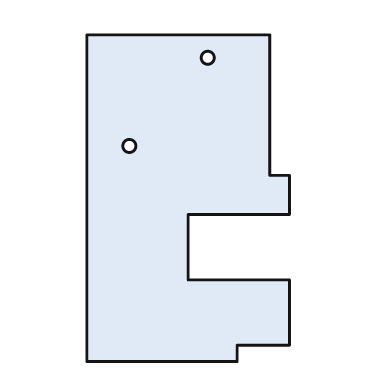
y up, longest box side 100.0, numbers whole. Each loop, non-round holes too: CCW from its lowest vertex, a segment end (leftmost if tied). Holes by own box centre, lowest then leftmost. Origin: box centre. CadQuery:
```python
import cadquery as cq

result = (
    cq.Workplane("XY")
    .moveTo(-31.0, -50.0)
    .lineTo(15.0, -50.0)
    .lineTo(15.0, -45.0)
    .lineTo(31.0, -45.0)
    .lineTo(31.0, -25.0)
    .lineTo(0.0, -25.0)
    .lineTo(0.0, -5.0)
    .lineTo(31.0, -5.0)
    .lineTo(31.0, 7.0)
    .lineTo(25.0, 7.0)
    .lineTo(25.0, 50.0)
    .lineTo(-31.0, 50.0)
    .close()
    .moveTo(-18.0, 16.0)
    .circle(2.0)
    .moveTo(6.0, 43.0)
    .circle(2.0)
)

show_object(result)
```